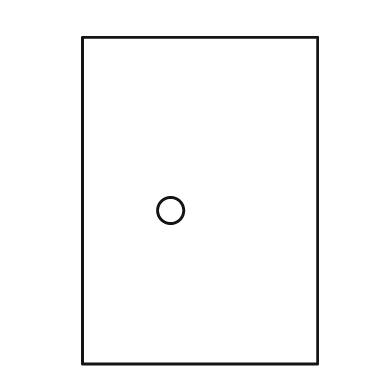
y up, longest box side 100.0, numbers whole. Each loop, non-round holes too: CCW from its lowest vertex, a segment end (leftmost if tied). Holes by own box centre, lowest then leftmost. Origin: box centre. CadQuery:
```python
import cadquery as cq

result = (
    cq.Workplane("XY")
    .moveTo(-36.0, -50.0)
    .lineTo(36.0, -50.0)
    .lineTo(36.0, 50.0)
    .lineTo(-36.0, 50.0)
    .close()
    .moveTo(-9.0, -3.0)
    .circle(4.0)
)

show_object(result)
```